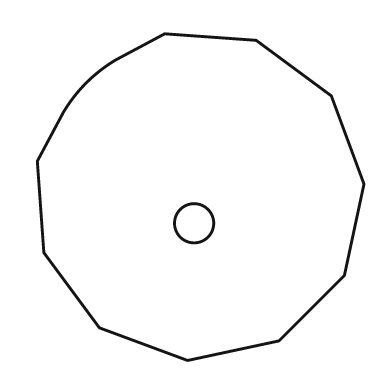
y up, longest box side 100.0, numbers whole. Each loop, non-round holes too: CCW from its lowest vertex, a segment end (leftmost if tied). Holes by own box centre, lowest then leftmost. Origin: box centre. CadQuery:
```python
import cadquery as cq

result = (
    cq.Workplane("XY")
    .moveTo(-4.0, -50.0)
    .lineTo(24.0, -44.0)
    .lineTo(44.0, -24.0)
    .lineTo(50.0, 4.0)
    .lineTo(40.0, 31.0)
    .lineTo(17.0, 48.0)
    .lineTo(-11.0, 50.0)
    .lineTo(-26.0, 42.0)
    .threePointArc((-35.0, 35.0), (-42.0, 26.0))
    .lineTo(-50.0, 11.0)
    .lineTo(-48.0, -17.0)
    .lineTo(-31.0, -40.0)
    .close()
    .moveTo(-2.0, -8.0)
    .circle(6.0)
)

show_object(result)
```